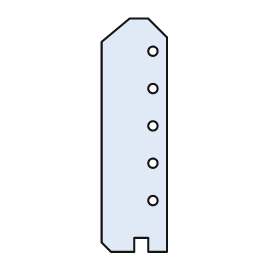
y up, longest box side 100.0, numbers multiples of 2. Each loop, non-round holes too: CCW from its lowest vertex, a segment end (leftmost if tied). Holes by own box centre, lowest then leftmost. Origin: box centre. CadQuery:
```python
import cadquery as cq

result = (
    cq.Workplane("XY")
    .moveTo(-10.0, -50.0)
    .lineTo(0.0, -50.0)
    .lineTo(0.0, -44.0)
    .lineTo(6.0, -44.0)
    .lineTo(6.0, -50.0)
    .lineTo(14.0, -50.0)
    .lineTo(14.0, 42.0)
    .lineTo(6.0, 50.0)
    .lineTo(-2.0, 50.0)
    .lineTo(-14.0, 40.0)
    .lineTo(-14.0, -46.0)
    .close()
    .moveTo(8.0, -28.0)
    .circle(2.0)
    .moveTo(8.0, -12.0)
    .circle(2.0)
    .moveTo(8.0, 4.0)
    .circle(2.0)
    .moveTo(8.0, 20.0)
    .circle(2.0)
    .moveTo(8.0, 36.0)
    .circle(2.0)
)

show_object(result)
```